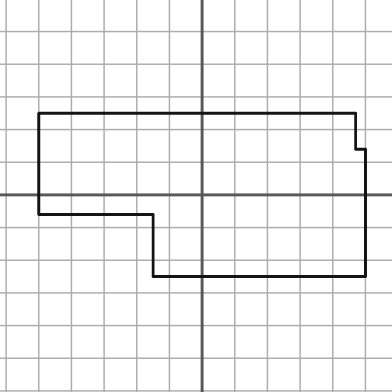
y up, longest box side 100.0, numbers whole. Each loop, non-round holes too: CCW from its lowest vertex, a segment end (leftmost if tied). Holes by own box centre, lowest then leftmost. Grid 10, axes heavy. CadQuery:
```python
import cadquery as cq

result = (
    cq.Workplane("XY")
    .moveTo(-15.0, -25.0)
    .lineTo(50.0, -25.0)
    .lineTo(50.0, 14.0)
    .lineTo(47.0, 14.0)
    .lineTo(47.0, 25.0)
    .lineTo(-50.0, 25.0)
    .lineTo(-50.0, -6.0)
    .lineTo(-15.0, -6.0)
    .close()
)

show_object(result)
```